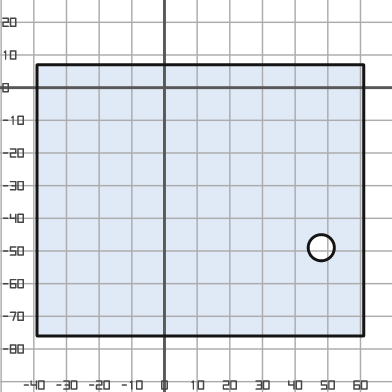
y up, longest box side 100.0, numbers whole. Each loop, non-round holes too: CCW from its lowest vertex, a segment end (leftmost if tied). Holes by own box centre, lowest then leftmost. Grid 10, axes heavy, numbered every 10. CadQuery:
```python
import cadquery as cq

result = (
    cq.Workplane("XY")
    .moveTo(-39.0, -76.0)
    .lineTo(61.0, -76.0)
    .lineTo(61.0, 7.0)
    .lineTo(-39.0, 7.0)
    .close()
    .moveTo(48.0, -49.0)
    .circle(4.0)
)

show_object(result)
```